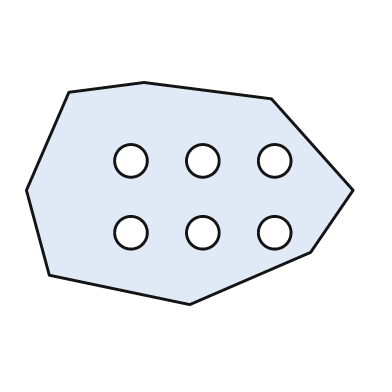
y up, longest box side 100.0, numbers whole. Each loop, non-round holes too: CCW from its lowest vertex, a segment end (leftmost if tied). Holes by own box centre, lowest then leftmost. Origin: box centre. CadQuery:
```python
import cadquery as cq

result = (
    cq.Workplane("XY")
    .moveTo(0.0, -34.0)
    .lineTo(37.0, -18.0)
    .lineTo(50.0, 1.0)
    .lineTo(25.0, 29.0)
    .lineTo(-14.0, 34.0)
    .lineTo(-37.0, 31.0)
    .lineTo(-50.0, 1.0)
    .lineTo(-43.0, -25.0)
    .close()
    .moveTo(-18.0, -12.0)
    .circle(5.0)
    .moveTo(4.0, -12.0)
    .circle(5.0)
    .moveTo(26.0, -12.0)
    .circle(5.0)
    .moveTo(-18.0, 10.0)
    .circle(5.0)
    .moveTo(4.0, 10.0)
    .circle(5.0)
    .moveTo(26.0, 10.0)
    .circle(5.0)
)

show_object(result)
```